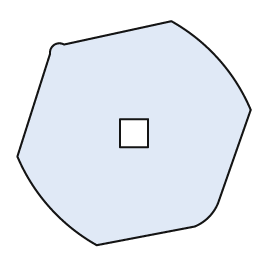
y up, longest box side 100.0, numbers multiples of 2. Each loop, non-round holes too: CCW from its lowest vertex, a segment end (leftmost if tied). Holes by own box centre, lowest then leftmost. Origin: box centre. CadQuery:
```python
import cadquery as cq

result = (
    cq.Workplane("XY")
    .moveTo(-16.0, -48.0)
    .lineTo(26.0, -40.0)
    .threePointArc((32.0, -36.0), (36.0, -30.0))
    .lineTo(50.0, 10.0)
    .threePointArc((36.0, 32.0), (16.0, 48.0))
    .lineTo(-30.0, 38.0)
    .threePointArc((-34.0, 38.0), (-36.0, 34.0))
    .lineTo(-50.0, -10.0)
    .threePointArc((-36.0, -32.0), (-16.0, -48.0))
    .close()
    .moveTo(-6.0, -6.0)
    .lineTo(6.0, -6.0)
    .lineTo(6.0, 6.0)
    .lineTo(-6.0, 6.0)
    .close()
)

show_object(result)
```